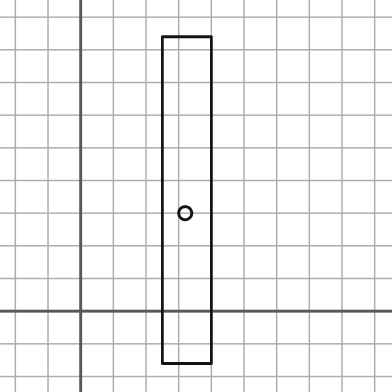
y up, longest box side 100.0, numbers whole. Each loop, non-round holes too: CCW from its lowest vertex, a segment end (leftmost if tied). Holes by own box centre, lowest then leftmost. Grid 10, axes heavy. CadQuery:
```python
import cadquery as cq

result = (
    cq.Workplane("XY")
    .moveTo(25.0, -16.0)
    .lineTo(40.0, -16.0)
    .lineTo(40.0, 84.0)
    .lineTo(25.0, 84.0)
    .close()
    .moveTo(32.0, 30.0)
    .circle(2.0)
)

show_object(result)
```